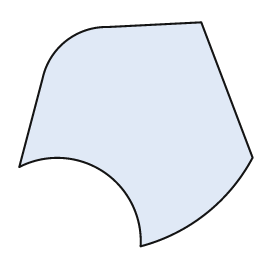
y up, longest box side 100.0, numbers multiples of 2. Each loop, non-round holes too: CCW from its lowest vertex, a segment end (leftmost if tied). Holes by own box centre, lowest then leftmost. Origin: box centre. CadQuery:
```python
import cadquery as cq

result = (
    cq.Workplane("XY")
    .moveTo(2.0, -48.0)
    .threePointArc((30.0, -34.0), (50.0, -10.0))
    .lineTo(28.0, 48.0)
    .lineTo(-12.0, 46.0)
    .threePointArc((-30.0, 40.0), (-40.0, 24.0))
    .lineTo(-50.0, -14.0)
    .threePointArc((-14.0, -16.0), (2.0, -48.0))
    .close()
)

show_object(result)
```